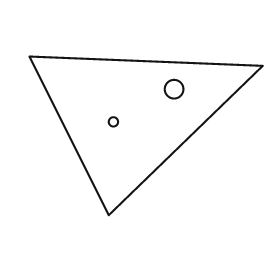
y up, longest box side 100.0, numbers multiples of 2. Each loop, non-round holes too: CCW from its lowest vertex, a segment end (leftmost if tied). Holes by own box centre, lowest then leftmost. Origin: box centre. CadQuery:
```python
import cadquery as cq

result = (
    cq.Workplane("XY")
    .moveTo(-16.0, -34.0)
    .lineTo(50.0, 30.0)
    .lineTo(-50.0, 34.0)
    .close()
    .moveTo(-14.0, 6.0)
    .circle(2.0)
    .moveTo(12.0, 20.0)
    .circle(4.0)
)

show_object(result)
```